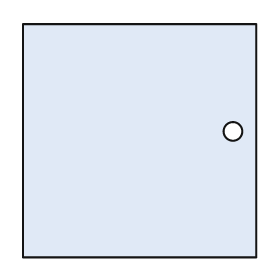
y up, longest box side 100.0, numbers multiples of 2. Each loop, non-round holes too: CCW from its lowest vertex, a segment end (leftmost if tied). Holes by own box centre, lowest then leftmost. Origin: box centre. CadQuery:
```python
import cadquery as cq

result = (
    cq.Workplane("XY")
    .moveTo(-50.0, -50.0)
    .lineTo(50.0, -50.0)
    .lineTo(50.0, 50.0)
    .lineTo(-50.0, 50.0)
    .close()
    .moveTo(40.0, 4.0)
    .circle(4.0)
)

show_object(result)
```